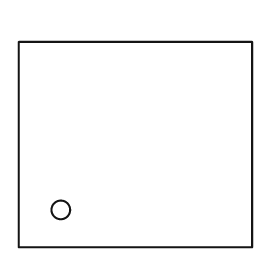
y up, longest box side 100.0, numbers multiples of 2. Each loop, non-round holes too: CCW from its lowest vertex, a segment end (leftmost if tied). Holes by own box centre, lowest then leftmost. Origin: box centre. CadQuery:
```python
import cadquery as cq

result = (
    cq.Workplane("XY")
    .moveTo(-50.0, -44.0)
    .lineTo(50.0, -44.0)
    .lineTo(50.0, 44.0)
    .lineTo(-50.0, 44.0)
    .close()
    .moveTo(-32.0, -28.0)
    .circle(4.0)
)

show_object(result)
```